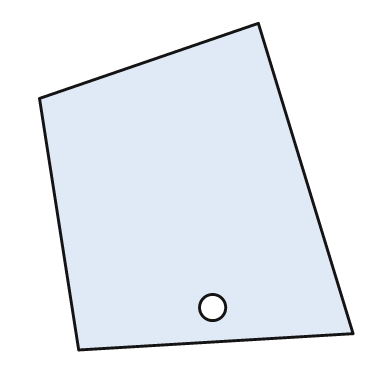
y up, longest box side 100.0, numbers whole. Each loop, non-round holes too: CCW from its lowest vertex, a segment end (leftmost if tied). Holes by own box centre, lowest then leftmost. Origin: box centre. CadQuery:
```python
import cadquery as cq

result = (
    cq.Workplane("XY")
    .moveTo(-36.0, -50.0)
    .lineTo(48.0, -45.0)
    .lineTo(19.0, 50.0)
    .lineTo(-48.0, 27.0)
    .close()
    .moveTo(5.0, -37.0)
    .circle(4.0)
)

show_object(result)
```